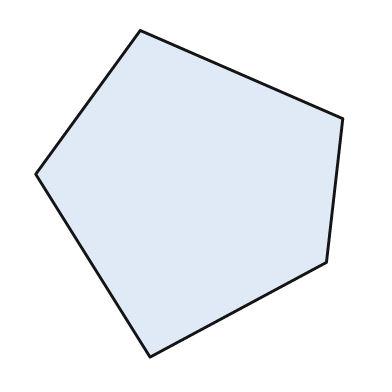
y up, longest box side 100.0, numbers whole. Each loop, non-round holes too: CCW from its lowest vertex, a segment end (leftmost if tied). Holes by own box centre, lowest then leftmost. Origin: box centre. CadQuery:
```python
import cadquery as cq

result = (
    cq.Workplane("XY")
    .moveTo(-12.0, -50.0)
    .lineTo(42.0, -21.0)
    .lineTo(47.0, 23.0)
    .lineTo(-15.0, 50.0)
    .lineTo(-47.0, 6.0)
    .close()
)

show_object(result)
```